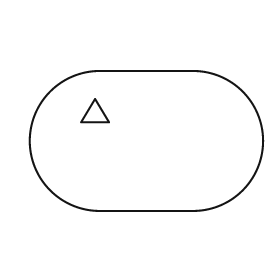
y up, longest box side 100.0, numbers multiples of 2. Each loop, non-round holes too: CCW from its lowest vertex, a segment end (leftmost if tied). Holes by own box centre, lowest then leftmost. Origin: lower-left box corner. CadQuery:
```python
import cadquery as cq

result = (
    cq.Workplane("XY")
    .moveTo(30.0, 0.0)
    .lineTo(70.0, 0.0)
    .threePointArc((100.0, 30.0), (70.0, 60.0))
    .lineTo(30.0, 60.0)
    .threePointArc((0.0, 30.0), (30.0, 0.0))
    .close()
    .moveTo(22.0, 38.0)
    .lineTo(34.0, 38.0)
    .lineTo(28.0, 48.0)
    .close()
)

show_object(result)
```